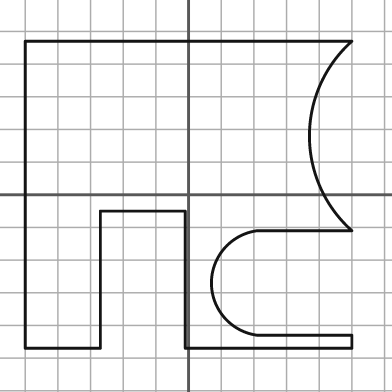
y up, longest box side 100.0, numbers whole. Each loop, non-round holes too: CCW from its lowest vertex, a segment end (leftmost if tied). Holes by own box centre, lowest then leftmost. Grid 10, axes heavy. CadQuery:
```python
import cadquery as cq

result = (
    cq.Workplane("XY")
    .moveTo(-50.0, -47.0)
    .lineTo(-27.0, -47.0)
    .lineTo(-27.0, -5.0)
    .lineTo(-1.0, -5.0)
    .lineTo(-1.0, -47.0)
    .lineTo(50.0, -47.0)
    .lineTo(50.0, -43.0)
    .lineTo(21.0, -43.0)
    .threePointArc((7.0, -27.0), (21.0, -11.0))
    .lineTo(50.0, -11.0)
    .threePointArc((37.0, 18.0), (50.0, 47.0))
    .lineTo(-50.0, 47.0)
    .close()
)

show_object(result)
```